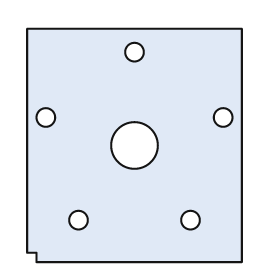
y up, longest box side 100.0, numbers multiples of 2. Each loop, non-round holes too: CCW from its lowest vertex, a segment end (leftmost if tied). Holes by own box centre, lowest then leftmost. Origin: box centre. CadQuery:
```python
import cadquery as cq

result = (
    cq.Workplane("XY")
    .moveTo(-42.0, -50.0)
    .lineTo(46.0, -50.0)
    .lineTo(46.0, 50.0)
    .lineTo(-46.0, 50.0)
    .lineTo(-46.0, -46.0)
    .lineTo(-42.0, -46.0)
    .close()
    .moveTo(-24.0, -32.0)
    .circle(4.0)
    .moveTo(24.0, -32.0)
    .circle(4.0)
    .moveTo(0.0, 0.0)
    .circle(10.0)
    .moveTo(-38.0, 12.0)
    .circle(4.0)
    .moveTo(38.0, 12.0)
    .circle(4.0)
    .moveTo(0.0, 40.0)
    .circle(4.0)
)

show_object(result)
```